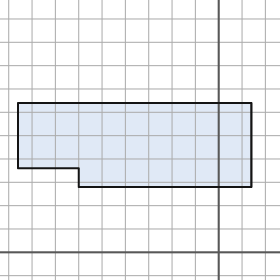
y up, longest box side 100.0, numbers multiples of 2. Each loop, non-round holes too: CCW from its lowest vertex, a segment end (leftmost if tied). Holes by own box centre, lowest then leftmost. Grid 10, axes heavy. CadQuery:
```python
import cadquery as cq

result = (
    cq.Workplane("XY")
    .moveTo(-60.0, 28.0)
    .lineTo(14.0, 28.0)
    .lineTo(14.0, 64.0)
    .lineTo(-86.0, 64.0)
    .lineTo(-86.0, 36.0)
    .lineTo(-60.0, 36.0)
    .close()
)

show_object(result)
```